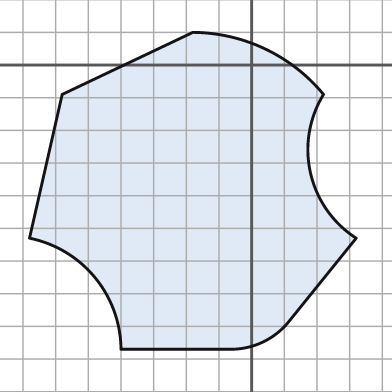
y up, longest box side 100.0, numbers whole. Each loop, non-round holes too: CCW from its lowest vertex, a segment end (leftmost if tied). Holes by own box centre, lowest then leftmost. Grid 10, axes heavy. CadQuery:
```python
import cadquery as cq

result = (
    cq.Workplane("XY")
    .moveTo(-40.0, -87.0)
    .lineTo(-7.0, -87.0)
    .threePointArc((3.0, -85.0), (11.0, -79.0))
    .lineTo(32.0, -53.0)
    .threePointArc((18.0, -33.0), (22.0, -9.0))
    .threePointArc((4.0, 5.0), (-18.0, 10.0))
    .lineTo(-58.0, -9.0)
    .lineTo(-68.0, -53.0)
    .threePointArc((-48.0, -65.0), (-40.0, -87.0))
    .close()
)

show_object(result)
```